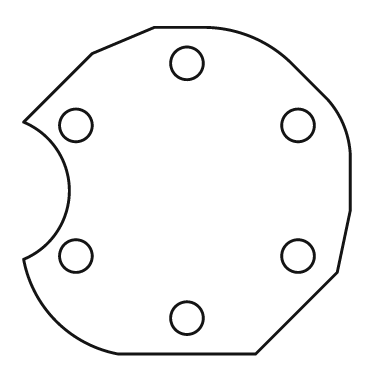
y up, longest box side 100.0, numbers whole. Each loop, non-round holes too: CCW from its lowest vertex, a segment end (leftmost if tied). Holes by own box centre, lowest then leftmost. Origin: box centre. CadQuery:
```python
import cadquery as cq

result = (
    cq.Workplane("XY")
    .moveTo(-21.0, -50.0)
    .lineTo(21.0, -50.0)
    .lineTo(46.0, -25.0)
    .lineTo(50.0, -6.0)
    .lineTo(50.0, 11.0)
    .threePointArc((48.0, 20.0), (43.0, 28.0))
    .lineTo(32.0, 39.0)
    .threePointArc((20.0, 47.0), (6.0, 50.0))
    .lineTo(-10.0, 50.0)
    .lineTo(-29.0, 42.0)
    .lineTo(-50.0, 21.0)
    .threePointArc((-36.0, 0.0), (-50.0, -21.0))
    .threePointArc((-40.0, -40.0), (-21.0, -50.0))
    .close()
    .moveTo(0.0, -39.0)
    .circle(5.0)
    .moveTo(-34.0, -20.0)
    .circle(5.0)
    .moveTo(34.0, -20.0)
    .circle(5.0)
    .moveTo(-34.0, 20.0)
    .circle(5.0)
    .moveTo(34.0, 20.0)
    .circle(5.0)
    .moveTo(0.0, 39.0)
    .circle(5.0)
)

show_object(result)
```